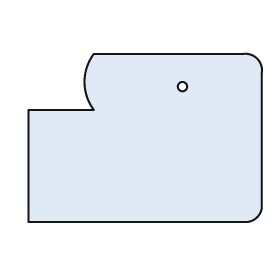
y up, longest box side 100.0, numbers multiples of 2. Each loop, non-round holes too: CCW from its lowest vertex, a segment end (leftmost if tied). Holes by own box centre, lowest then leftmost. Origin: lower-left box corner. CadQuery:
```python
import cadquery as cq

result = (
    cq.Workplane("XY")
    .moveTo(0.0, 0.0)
    .lineTo(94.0, 0.0)
    .threePointArc((98.0, 2.0), (100.0, 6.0))
    .lineTo(100.0, 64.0)
    .threePointArc((98.0, 70.0), (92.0, 72.0))
    .lineTo(28.0, 72.0)
    .threePointArc((24.0, 60.0), (28.0, 48.0))
    .lineTo(0.0, 48.0)
    .close()
    .moveTo(66.0, 58.0)
    .circle(2.0)
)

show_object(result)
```